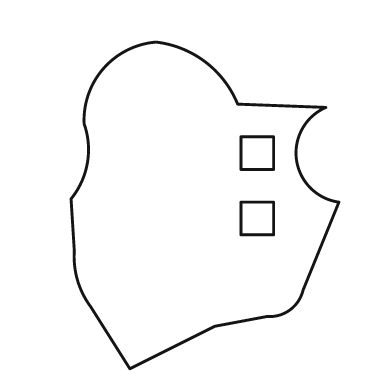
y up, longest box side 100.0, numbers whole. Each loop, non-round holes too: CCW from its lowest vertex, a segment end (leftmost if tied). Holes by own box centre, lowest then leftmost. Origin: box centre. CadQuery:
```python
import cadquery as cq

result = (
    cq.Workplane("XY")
    .moveTo(-23.0, -50.0)
    .lineTo(3.0, -37.0)
    .lineTo(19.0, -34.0)
    .threePointArc((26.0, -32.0), (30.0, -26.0))
    .lineTo(41.0, 1.0)
    .threePointArc((28.0, 14.0), (37.0, 30.0))
    .lineTo(10.0, 31.0)
    .threePointArc((0.0, 44.0), (-15.0, 50.0))
    .threePointArc((-31.0, 42.0), (-37.0, 25.0))
    .threePointArc((-36.0, 13.0), (-41.0, 2.0))
    .lineTo(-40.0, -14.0)
    .threePointArc((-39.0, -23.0), (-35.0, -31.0))
    .close()
    .moveTo(11.0, -9.0)
    .lineTo(21.0, -9.0)
    .lineTo(21.0, 1.0)
    .lineTo(11.0, 1.0)
    .close()
    .moveTo(11.0, 11.0)
    .lineTo(21.0, 11.0)
    .lineTo(21.0, 21.0)
    .lineTo(11.0, 21.0)
    .close()
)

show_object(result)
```